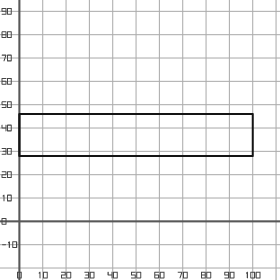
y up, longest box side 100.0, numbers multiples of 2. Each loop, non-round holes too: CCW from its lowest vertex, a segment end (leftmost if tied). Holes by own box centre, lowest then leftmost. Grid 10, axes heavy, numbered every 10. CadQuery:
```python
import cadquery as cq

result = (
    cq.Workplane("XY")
    .moveTo(0.0, 28.0)
    .lineTo(100.0, 28.0)
    .lineTo(100.0, 46.0)
    .lineTo(0.0, 46.0)
    .close()
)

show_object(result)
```